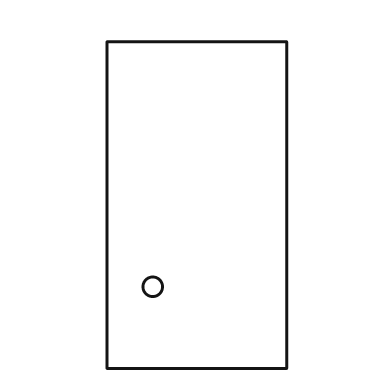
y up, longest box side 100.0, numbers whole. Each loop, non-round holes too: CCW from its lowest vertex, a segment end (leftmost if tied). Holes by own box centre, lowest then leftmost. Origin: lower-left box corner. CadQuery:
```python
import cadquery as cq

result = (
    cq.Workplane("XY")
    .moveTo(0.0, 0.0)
    .lineTo(55.0, 0.0)
    .lineTo(55.0, 100.0)
    .lineTo(0.0, 100.0)
    .close()
    .moveTo(14.0, 25.0)
    .circle(3.0)
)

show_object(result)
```